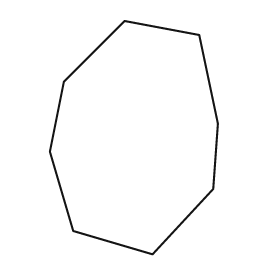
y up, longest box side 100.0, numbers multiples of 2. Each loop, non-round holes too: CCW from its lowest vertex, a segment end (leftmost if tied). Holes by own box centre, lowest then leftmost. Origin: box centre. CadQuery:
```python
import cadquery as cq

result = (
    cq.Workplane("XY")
    .moveTo(8.0, -50.0)
    .lineTo(34.0, -22.0)
    .lineTo(36.0, 6.0)
    .lineTo(28.0, 44.0)
    .lineTo(-4.0, 50.0)
    .lineTo(-30.0, 24.0)
    .lineTo(-36.0, -6.0)
    .lineTo(-26.0, -40.0)
    .close()
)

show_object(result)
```